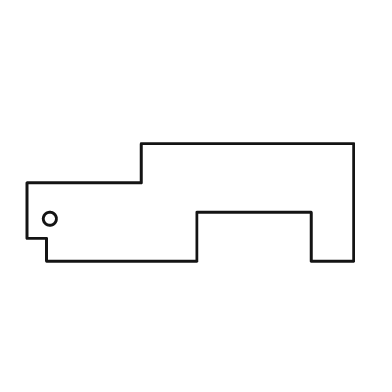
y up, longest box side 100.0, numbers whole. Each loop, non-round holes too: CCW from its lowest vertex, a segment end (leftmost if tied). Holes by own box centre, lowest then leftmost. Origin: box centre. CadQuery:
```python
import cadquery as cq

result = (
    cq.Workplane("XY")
    .moveTo(-44.0, -18.0)
    .lineTo(2.0, -18.0)
    .lineTo(2.0, -3.0)
    .lineTo(37.0, -3.0)
    .lineTo(37.0, -18.0)
    .lineTo(50.0, -18.0)
    .lineTo(50.0, 18.0)
    .lineTo(-15.0, 18.0)
    .lineTo(-15.0, 6.0)
    .lineTo(-50.0, 6.0)
    .lineTo(-50.0, -11.0)
    .lineTo(-44.0, -11.0)
    .close()
    .moveTo(-43.0, -5.0)
    .circle(2.0)
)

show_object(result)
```